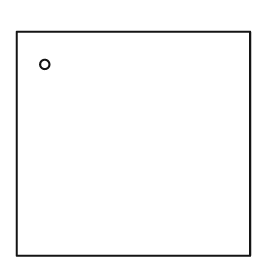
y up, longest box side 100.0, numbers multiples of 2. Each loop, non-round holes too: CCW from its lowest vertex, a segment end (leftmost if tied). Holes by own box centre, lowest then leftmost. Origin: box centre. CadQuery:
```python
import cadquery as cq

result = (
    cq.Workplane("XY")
    .moveTo(-50.0, -48.0)
    .lineTo(50.0, -48.0)
    .lineTo(50.0, 48.0)
    .lineTo(-50.0, 48.0)
    .close()
    .moveTo(-38.0, 34.0)
    .circle(2.0)
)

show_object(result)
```